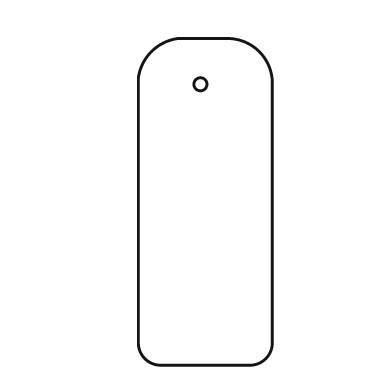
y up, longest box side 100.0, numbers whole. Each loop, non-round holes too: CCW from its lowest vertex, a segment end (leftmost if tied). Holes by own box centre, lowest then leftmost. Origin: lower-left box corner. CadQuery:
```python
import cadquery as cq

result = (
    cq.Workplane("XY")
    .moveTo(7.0, 0.0)
    .lineTo(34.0, 0.0)
    .threePointArc((39.0, 2.0), (41.0, 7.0))
    .lineTo(41.0, 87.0)
    .threePointArc((37.0, 96.0), (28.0, 100.0))
    .lineTo(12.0, 100.0)
    .threePointArc((4.0, 96.0), (0.0, 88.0))
    .lineTo(0.0, 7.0)
    .threePointArc((2.0, 2.0), (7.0, 0.0))
    .close()
    .moveTo(19.0, 86.0)
    .circle(2.0)
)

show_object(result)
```